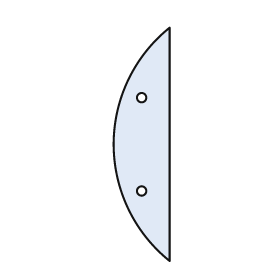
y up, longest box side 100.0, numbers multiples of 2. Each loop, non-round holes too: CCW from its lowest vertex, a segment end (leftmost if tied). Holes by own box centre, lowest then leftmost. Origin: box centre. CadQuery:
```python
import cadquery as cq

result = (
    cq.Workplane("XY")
    .moveTo(12.0, -50.0)
    .lineTo(12.0, 50.0)
    .threePointArc((-12.0, 0.0), (12.0, -50.0))
    .close()
    .moveTo(0.0, -20.0)
    .circle(2.0)
    .moveTo(0.0, 20.0)
    .circle(2.0)
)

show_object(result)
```